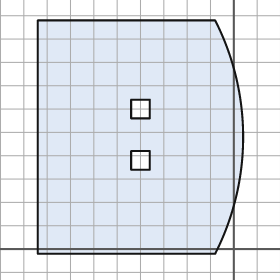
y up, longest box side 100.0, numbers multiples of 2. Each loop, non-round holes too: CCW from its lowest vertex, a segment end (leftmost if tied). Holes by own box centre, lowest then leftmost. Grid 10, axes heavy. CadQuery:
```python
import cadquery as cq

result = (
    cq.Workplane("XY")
    .moveTo(-84.0, -2.0)
    .lineTo(-8.0, -2.0)
    .threePointArc((4.0, 48.0), (-8.0, 98.0))
    .lineTo(-84.0, 98.0)
    .close()
    .moveTo(-44.0, 34.0)
    .lineTo(-36.0, 34.0)
    .lineTo(-36.0, 42.0)
    .lineTo(-44.0, 42.0)
    .close()
    .moveTo(-44.0, 56.0)
    .lineTo(-36.0, 56.0)
    .lineTo(-36.0, 64.0)
    .lineTo(-44.0, 64.0)
    .close()
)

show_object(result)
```